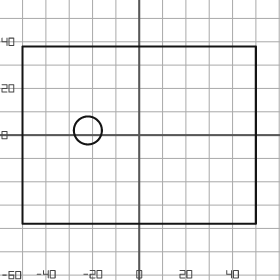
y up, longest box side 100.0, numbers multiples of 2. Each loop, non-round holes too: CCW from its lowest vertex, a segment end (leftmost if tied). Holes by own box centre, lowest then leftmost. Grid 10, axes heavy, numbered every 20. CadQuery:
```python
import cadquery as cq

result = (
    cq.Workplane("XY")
    .moveTo(-50.0, -38.0)
    .lineTo(50.0, -38.0)
    .lineTo(50.0, 38.0)
    .lineTo(-50.0, 38.0)
    .close()
    .moveTo(-22.0, 2.0)
    .circle(6.0)
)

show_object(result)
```